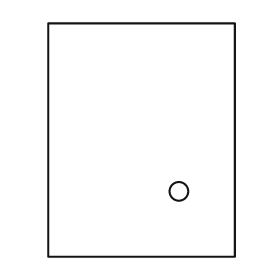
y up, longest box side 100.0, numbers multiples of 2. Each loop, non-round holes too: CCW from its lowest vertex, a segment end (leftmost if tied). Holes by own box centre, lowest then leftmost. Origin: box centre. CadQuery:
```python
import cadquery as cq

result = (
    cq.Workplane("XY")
    .moveTo(-40.0, -50.0)
    .lineTo(40.0, -50.0)
    .lineTo(40.0, 50.0)
    .lineTo(-40.0, 50.0)
    .close()
    .moveTo(16.0, -22.0)
    .circle(4.0)
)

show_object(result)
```